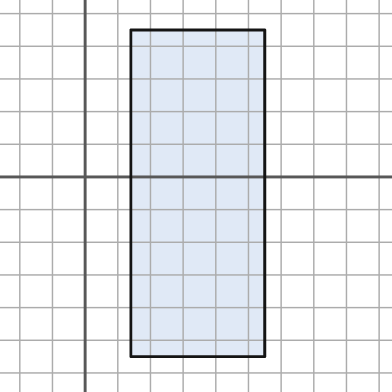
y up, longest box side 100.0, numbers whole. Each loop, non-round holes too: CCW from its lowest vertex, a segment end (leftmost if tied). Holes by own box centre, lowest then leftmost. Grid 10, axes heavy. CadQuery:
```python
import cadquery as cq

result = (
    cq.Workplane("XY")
    .moveTo(14.0, -55.0)
    .lineTo(55.0, -55.0)
    .lineTo(55.0, 45.0)
    .lineTo(14.0, 45.0)
    .close()
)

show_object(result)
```